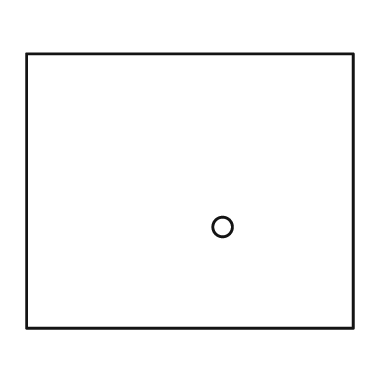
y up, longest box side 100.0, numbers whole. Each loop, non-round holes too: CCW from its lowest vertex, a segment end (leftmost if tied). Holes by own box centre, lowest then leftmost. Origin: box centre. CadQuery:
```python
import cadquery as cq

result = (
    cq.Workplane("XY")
    .moveTo(-50.0, -42.0)
    .lineTo(50.0, -42.0)
    .lineTo(50.0, 42.0)
    .lineTo(-50.0, 42.0)
    .close()
    .moveTo(10.0, -11.0)
    .circle(3.0)
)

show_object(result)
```